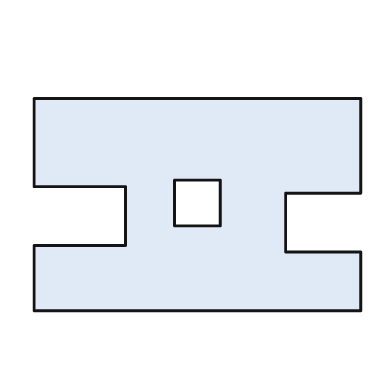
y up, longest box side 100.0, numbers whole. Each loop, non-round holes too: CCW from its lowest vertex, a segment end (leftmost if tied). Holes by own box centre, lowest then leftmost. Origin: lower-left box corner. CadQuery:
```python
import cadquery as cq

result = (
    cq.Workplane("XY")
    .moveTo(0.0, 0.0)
    .lineTo(100.0, 0.0)
    .lineTo(100.0, 18.0)
    .lineTo(77.0, 18.0)
    .lineTo(77.0, 36.0)
    .lineTo(100.0, 36.0)
    .lineTo(100.0, 65.0)
    .lineTo(0.0, 65.0)
    .lineTo(0.0, 38.0)
    .lineTo(28.0, 38.0)
    .lineTo(28.0, 20.0)
    .lineTo(0.0, 20.0)
    .close()
    .moveTo(43.0, 26.0)
    .lineTo(57.0, 26.0)
    .lineTo(57.0, 40.0)
    .lineTo(43.0, 40.0)
    .close()
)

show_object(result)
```